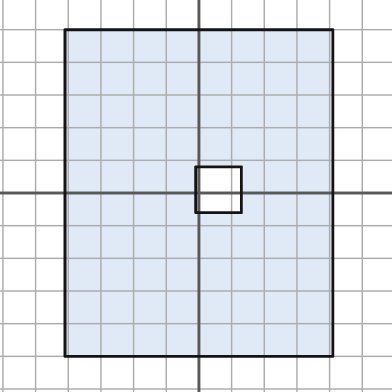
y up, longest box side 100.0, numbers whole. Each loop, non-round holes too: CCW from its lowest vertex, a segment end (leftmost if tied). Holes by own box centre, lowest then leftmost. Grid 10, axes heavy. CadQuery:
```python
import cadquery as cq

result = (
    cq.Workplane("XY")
    .moveTo(-41.0, -50.0)
    .lineTo(41.0, -50.0)
    .lineTo(41.0, 50.0)
    .lineTo(-41.0, 50.0)
    .close()
    .moveTo(-1.0, -6.0)
    .lineTo(13.0, -6.0)
    .lineTo(13.0, 8.0)
    .lineTo(-1.0, 8.0)
    .close()
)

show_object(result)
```